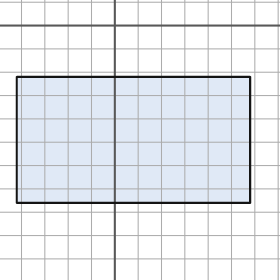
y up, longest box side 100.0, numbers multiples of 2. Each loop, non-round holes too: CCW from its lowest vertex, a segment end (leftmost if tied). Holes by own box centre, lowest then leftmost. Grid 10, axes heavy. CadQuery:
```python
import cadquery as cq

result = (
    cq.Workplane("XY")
    .moveTo(-42.0, -76.0)
    .lineTo(58.0, -76.0)
    .lineTo(58.0, -22.0)
    .lineTo(-42.0, -22.0)
    .close()
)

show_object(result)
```